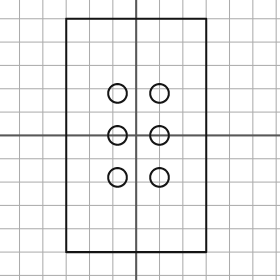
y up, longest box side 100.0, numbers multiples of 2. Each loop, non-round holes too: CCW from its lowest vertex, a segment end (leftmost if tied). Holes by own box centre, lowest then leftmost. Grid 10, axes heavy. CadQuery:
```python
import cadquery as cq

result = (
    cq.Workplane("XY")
    .moveTo(-30.0, -50.0)
    .lineTo(30.0, -50.0)
    .lineTo(30.0, 50.0)
    .lineTo(-30.0, 50.0)
    .close()
    .moveTo(-8.0, -18.0)
    .circle(4.0)
    .moveTo(10.0, -18.0)
    .circle(4.0)
    .moveTo(-8.0, 0.0)
    .circle(4.0)
    .moveTo(10.0, 0.0)
    .circle(4.0)
    .moveTo(-8.0, 18.0)
    .circle(4.0)
    .moveTo(10.0, 18.0)
    .circle(4.0)
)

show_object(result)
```